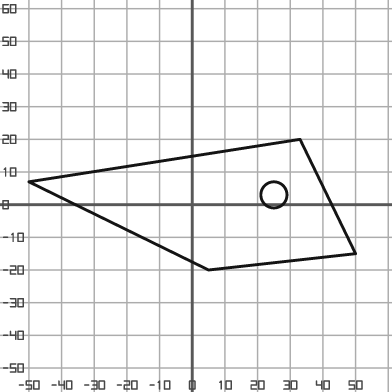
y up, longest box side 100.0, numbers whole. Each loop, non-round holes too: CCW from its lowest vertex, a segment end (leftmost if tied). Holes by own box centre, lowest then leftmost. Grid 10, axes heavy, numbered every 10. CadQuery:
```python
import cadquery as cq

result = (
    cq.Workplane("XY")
    .moveTo(5.0, -20.0)
    .lineTo(50.0, -15.0)
    .lineTo(33.0, 20.0)
    .lineTo(-50.0, 7.0)
    .close()
    .moveTo(25.0, 3.0)
    .circle(4.0)
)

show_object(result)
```